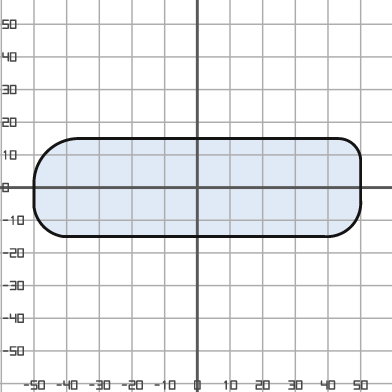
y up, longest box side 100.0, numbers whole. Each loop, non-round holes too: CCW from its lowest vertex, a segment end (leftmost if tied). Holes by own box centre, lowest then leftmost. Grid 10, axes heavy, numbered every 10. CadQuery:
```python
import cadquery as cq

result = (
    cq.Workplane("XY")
    .moveTo(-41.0, -15.0)
    .lineTo(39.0, -15.0)
    .threePointArc((47.0, -12.0), (50.0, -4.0))
    .lineTo(50.0, 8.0)
    .threePointArc((48.0, 13.0), (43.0, 15.0))
    .lineTo(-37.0, 15.0)
    .threePointArc((-46.0, 11.0), (-50.0, 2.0))
    .lineTo(-50.0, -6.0)
    .threePointArc((-47.0, -12.0), (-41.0, -15.0))
    .close()
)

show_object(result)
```